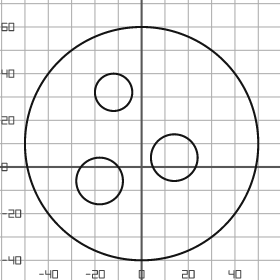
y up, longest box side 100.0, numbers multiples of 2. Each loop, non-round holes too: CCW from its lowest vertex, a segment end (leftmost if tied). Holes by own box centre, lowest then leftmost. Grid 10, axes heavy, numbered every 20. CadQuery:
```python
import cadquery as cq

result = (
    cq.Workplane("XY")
    .moveTo(0.0, 10.0)
    .circle(50.0)
    .moveTo(-18.0, -6.0)
    .circle(10.0)
    .moveTo(14.0, 4.0)
    .circle(10.0)
    .moveTo(-12.0, 32.0)
    .circle(8.0)
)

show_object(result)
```